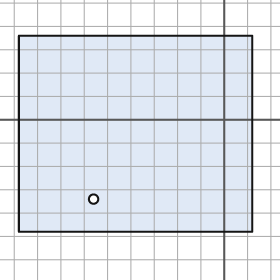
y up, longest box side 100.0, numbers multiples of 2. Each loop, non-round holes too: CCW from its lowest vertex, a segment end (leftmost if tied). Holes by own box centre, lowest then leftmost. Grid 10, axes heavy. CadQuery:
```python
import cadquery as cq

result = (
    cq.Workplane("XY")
    .moveTo(-88.0, -48.0)
    .lineTo(12.0, -48.0)
    .lineTo(12.0, 36.0)
    .lineTo(-88.0, 36.0)
    .close()
    .moveTo(-56.0, -34.0)
    .circle(2.0)
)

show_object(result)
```